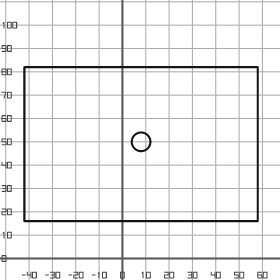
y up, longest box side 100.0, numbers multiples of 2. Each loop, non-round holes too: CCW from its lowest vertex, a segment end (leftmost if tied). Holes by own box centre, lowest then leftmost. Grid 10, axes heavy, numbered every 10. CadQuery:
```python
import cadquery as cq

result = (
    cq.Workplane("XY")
    .moveTo(-42.0, 16.0)
    .lineTo(58.0, 16.0)
    .lineTo(58.0, 82.0)
    .lineTo(-42.0, 82.0)
    .close()
    .moveTo(8.0, 50.0)
    .circle(4.0)
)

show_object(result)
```